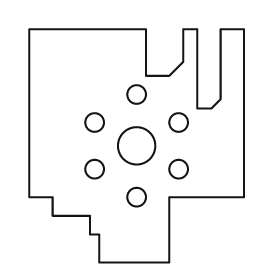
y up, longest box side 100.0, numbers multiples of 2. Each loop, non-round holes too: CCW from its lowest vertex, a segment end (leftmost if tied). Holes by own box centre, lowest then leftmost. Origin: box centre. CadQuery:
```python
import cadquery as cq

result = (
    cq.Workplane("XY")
    .moveTo(-16.0, -50.0)
    .lineTo(14.0, -50.0)
    .lineTo(14.0, -22.0)
    .lineTo(46.0, -22.0)
    .lineTo(46.0, 50.0)
    .lineTo(36.0, 50.0)
    .lineTo(36.0, 20.0)
    .lineTo(32.0, 16.0)
    .lineTo(26.0, 16.0)
    .lineTo(26.0, 50.0)
    .lineTo(20.0, 50.0)
    .lineTo(20.0, 36.0)
    .lineTo(14.0, 30.0)
    .lineTo(4.0, 30.0)
    .lineTo(4.0, 50.0)
    .lineTo(-46.0, 50.0)
    .lineTo(-46.0, -22.0)
    .lineTo(-36.0, -22.0)
    .lineTo(-36.0, -30.0)
    .lineTo(-20.0, -30.0)
    .lineTo(-20.0, -38.0)
    .lineTo(-16.0, -38.0)
    .close()
    .moveTo(0.0, -22.0)
    .circle(4.0)
    .moveTo(-18.0, -10.0)
    .circle(4.0)
    .moveTo(18.0, -10.0)
    .circle(4.0)
    .moveTo(0.0, 0.0)
    .circle(8.0)
    .moveTo(-18.0, 10.0)
    .circle(4.0)
    .moveTo(18.0, 10.0)
    .circle(4.0)
    .moveTo(0.0, 22.0)
    .circle(4.0)
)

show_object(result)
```